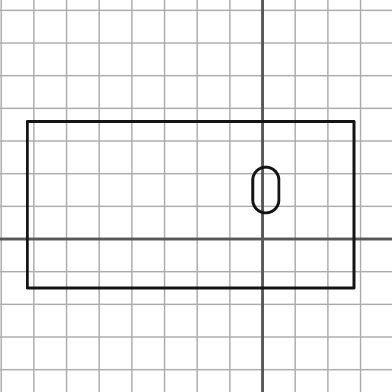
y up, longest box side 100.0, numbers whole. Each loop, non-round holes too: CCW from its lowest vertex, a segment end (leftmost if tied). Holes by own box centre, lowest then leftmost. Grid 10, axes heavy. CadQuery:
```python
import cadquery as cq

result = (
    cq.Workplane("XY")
    .moveTo(-72.0, -15.0)
    .lineTo(28.0, -15.0)
    .lineTo(28.0, 36.0)
    .lineTo(-72.0, 36.0)
    .close()
    .moveTo(-3.0, 12.0)
    .threePointArc((1.0, 8.0), (5.0, 12.0))
    .lineTo(5.0, 18.0)
    .threePointArc((1.0, 22.0), (-3.0, 18.0))
    .close()
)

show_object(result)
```